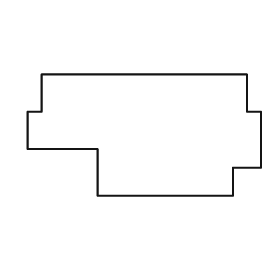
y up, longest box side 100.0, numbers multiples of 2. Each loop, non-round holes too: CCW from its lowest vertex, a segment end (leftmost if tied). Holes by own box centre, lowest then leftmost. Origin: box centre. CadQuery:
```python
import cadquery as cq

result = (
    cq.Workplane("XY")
    .moveTo(-20.0, -26.0)
    .lineTo(38.0, -26.0)
    .lineTo(38.0, -14.0)
    .lineTo(50.0, -14.0)
    .lineTo(50.0, 10.0)
    .lineTo(44.0, 10.0)
    .lineTo(44.0, 26.0)
    .lineTo(-44.0, 26.0)
    .lineTo(-44.0, 10.0)
    .lineTo(-50.0, 10.0)
    .lineTo(-50.0, -6.0)
    .lineTo(-20.0, -6.0)
    .close()
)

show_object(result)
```